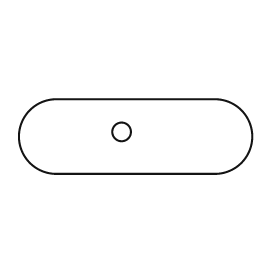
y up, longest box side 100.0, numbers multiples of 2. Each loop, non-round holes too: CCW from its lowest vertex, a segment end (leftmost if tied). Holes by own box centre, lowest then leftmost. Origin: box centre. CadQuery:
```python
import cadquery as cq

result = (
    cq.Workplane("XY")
    .moveTo(-34.0, -16.0)
    .lineTo(34.0, -16.0)
    .threePointArc((50.0, 0.0), (34.0, 16.0))
    .lineTo(-34.0, 16.0)
    .threePointArc((-50.0, 0.0), (-34.0, -16.0))
    .close()
    .moveTo(-6.0, 2.0)
    .circle(4.0)
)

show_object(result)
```